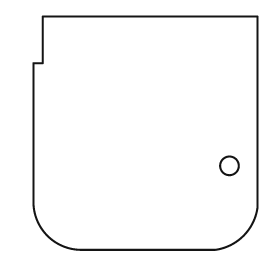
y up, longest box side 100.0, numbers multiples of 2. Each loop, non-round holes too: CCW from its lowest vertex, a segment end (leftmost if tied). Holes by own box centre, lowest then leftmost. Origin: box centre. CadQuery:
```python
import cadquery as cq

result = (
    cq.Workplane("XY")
    .moveTo(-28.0, -50.0)
    .lineTo(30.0, -50.0)
    .threePointArc((42.0, -44.0), (48.0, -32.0))
    .lineTo(48.0, 50.0)
    .lineTo(-44.0, 50.0)
    .lineTo(-44.0, 30.0)
    .lineTo(-48.0, 30.0)
    .lineTo(-48.0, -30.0)
    .threePointArc((-42.0, -44.0), (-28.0, -50.0))
    .close()
    .moveTo(36.0, -14.0)
    .circle(4.0)
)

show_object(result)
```